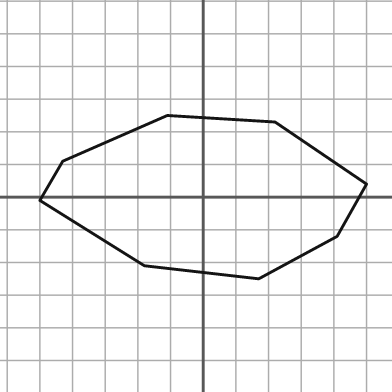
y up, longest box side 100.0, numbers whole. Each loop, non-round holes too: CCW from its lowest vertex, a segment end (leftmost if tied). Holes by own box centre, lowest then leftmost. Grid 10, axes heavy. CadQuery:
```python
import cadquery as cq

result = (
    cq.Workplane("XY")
    .moveTo(17.0, -25.0)
    .lineTo(41.0, -12.0)
    .lineTo(50.0, 4.0)
    .lineTo(22.0, 23.0)
    .lineTo(-11.0, 25.0)
    .lineTo(-43.0, 11.0)
    .lineTo(-50.0, -1.0)
    .lineTo(-18.0, -21.0)
    .close()
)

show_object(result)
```